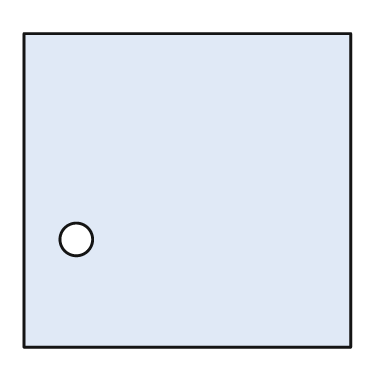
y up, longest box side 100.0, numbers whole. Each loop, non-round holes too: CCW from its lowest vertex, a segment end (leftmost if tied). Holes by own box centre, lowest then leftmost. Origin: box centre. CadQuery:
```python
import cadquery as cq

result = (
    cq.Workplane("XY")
    .moveTo(-50.0, -48.0)
    .lineTo(50.0, -48.0)
    .lineTo(50.0, 48.0)
    .lineTo(-50.0, 48.0)
    .close()
    .moveTo(-34.0, -15.0)
    .circle(5.0)
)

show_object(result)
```